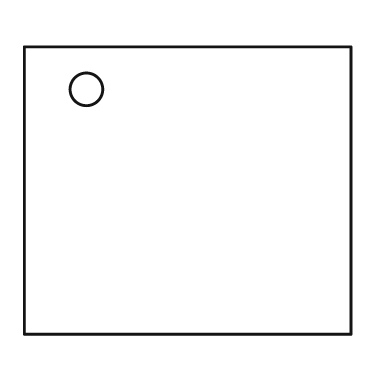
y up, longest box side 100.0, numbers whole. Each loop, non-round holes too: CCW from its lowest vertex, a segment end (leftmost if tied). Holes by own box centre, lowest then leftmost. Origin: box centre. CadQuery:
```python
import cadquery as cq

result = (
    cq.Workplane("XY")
    .moveTo(-50.0, -44.0)
    .lineTo(50.0, -44.0)
    .lineTo(50.0, 44.0)
    .lineTo(-50.0, 44.0)
    .close()
    .moveTo(-31.0, 31.0)
    .circle(5.0)
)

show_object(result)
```